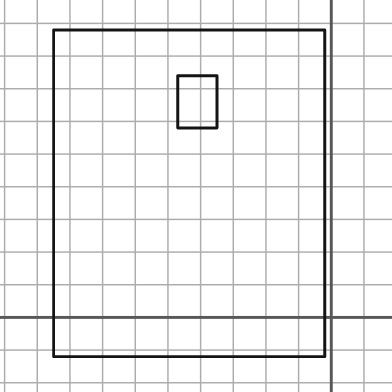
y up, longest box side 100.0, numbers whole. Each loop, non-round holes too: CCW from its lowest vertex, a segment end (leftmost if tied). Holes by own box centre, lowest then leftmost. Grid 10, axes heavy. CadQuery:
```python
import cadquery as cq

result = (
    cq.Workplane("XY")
    .moveTo(-85.0, -12.0)
    .lineTo(-2.0, -12.0)
    .lineTo(-2.0, 88.0)
    .lineTo(-85.0, 88.0)
    .close()
    .moveTo(-47.0, 58.0)
    .lineTo(-35.0, 58.0)
    .lineTo(-35.0, 74.0)
    .lineTo(-47.0, 74.0)
    .close()
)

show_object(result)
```